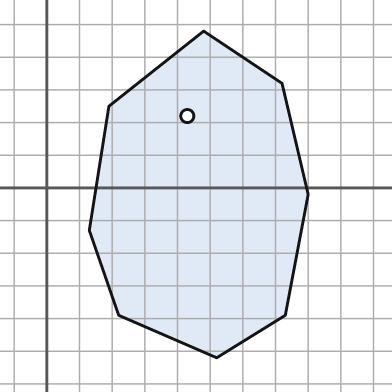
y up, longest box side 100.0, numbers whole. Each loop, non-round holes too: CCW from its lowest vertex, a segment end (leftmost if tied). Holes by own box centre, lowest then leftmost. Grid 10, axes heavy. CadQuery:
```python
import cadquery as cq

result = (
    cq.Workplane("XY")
    .moveTo(52.0, -52.0)
    .lineTo(73.0, -39.0)
    .lineTo(80.0, -2.0)
    .lineTo(72.0, 32.0)
    .lineTo(48.0, 48.0)
    .lineTo(19.0, 25.0)
    .lineTo(13.0, -13.0)
    .lineTo(22.0, -39.0)
    .close()
    .moveTo(43.0, 22.0)
    .circle(2.0)
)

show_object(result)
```